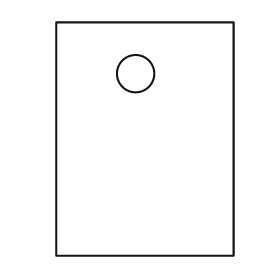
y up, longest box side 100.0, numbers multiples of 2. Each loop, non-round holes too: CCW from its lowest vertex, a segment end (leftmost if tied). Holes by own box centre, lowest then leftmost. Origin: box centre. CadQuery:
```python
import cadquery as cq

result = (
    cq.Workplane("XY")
    .moveTo(-38.0, -50.0)
    .lineTo(38.0, -50.0)
    .lineTo(38.0, 50.0)
    .lineTo(-38.0, 50.0)
    .close()
    .moveTo(-4.0, 28.0)
    .circle(8.0)
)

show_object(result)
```